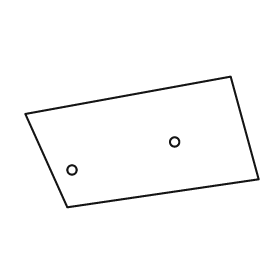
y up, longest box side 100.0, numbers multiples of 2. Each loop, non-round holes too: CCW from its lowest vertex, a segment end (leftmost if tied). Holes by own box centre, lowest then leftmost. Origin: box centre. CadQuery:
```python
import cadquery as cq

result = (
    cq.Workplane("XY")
    .moveTo(-32.0, -28.0)
    .lineTo(50.0, -16.0)
    .lineTo(38.0, 28.0)
    .lineTo(-50.0, 12.0)
    .close()
    .moveTo(-30.0, -12.0)
    .circle(2.0)
    .moveTo(14.0, 0.0)
    .circle(2.0)
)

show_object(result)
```